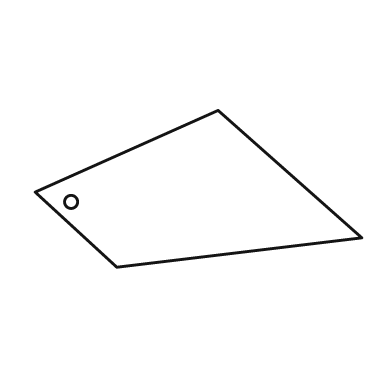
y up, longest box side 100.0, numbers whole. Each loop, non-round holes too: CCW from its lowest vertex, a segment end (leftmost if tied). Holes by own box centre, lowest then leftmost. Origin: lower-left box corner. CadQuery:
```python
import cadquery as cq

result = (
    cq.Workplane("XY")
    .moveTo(25.0, 0.0)
    .lineTo(100.0, 9.0)
    .lineTo(56.0, 48.0)
    .lineTo(0.0, 23.0)
    .close()
    .moveTo(11.0, 20.0)
    .circle(2.0)
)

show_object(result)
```